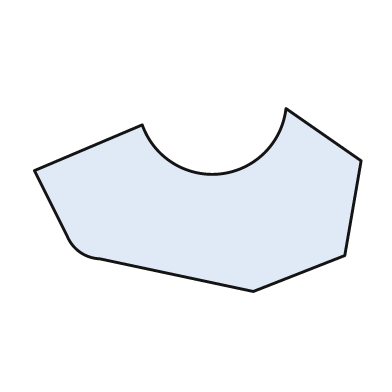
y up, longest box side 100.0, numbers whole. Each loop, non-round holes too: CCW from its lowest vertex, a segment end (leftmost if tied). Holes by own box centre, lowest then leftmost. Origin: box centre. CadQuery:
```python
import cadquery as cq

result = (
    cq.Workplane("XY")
    .moveTo(17.0, -28.0)
    .lineTo(45.0, -17.0)
    .lineTo(50.0, 12.0)
    .lineTo(27.0, 28.0)
    .threePointArc((7.0, 8.0), (-17.0, 23.0))
    .lineTo(-50.0, 9.0)
    .lineTo(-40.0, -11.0)
    .threePointArc((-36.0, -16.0), (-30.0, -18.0))
    .close()
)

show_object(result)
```